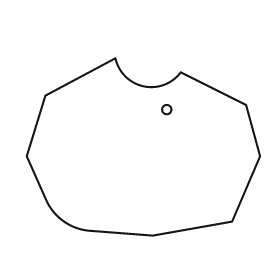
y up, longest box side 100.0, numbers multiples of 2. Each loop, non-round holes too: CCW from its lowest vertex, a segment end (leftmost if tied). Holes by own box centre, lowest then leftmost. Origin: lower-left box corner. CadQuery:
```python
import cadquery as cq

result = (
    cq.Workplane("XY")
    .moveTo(54.0, 0.0)
    .lineTo(88.0, 6.0)
    .lineTo(100.0, 34.0)
    .lineTo(94.0, 56.0)
    .lineTo(66.0, 70.0)
    .threePointArc((50.0, 64.0), (38.0, 76.0))
    .lineTo(8.0, 60.0)
    .lineTo(0.0, 34.0)
    .lineTo(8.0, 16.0)
    .threePointArc((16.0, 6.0), (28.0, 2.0))
    .close()
    .moveTo(60.0, 54.0)
    .circle(2.0)
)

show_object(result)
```